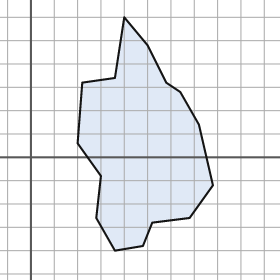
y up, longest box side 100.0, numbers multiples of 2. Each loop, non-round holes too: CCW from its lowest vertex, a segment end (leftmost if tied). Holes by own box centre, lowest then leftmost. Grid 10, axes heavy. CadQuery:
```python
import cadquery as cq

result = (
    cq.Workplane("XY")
    .moveTo(36.0, -40.0)
    .lineTo(48.0, -38.0)
    .lineTo(52.0, -28.0)
    .lineTo(68.0, -26.0)
    .lineTo(78.0, -12.0)
    .lineTo(72.0, 14.0)
    .lineTo(64.0, 28.0)
    .lineTo(58.0, 32.0)
    .lineTo(50.0, 48.0)
    .lineTo(40.0, 60.0)
    .lineTo(36.0, 34.0)
    .lineTo(22.0, 32.0)
    .lineTo(20.0, 6.0)
    .lineTo(30.0, -8.0)
    .lineTo(28.0, -26.0)
    .close()
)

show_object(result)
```